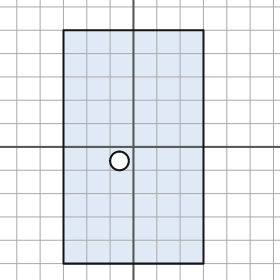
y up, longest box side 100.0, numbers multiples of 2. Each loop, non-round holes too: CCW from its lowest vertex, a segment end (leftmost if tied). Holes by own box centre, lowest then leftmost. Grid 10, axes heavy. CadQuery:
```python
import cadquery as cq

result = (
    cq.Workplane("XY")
    .moveTo(-30.0, -50.0)
    .lineTo(30.0, -50.0)
    .lineTo(30.0, 50.0)
    .lineTo(-30.0, 50.0)
    .close()
    .moveTo(-6.0, -6.0)
    .circle(4.0)
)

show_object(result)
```